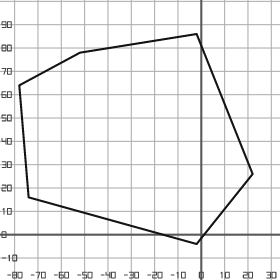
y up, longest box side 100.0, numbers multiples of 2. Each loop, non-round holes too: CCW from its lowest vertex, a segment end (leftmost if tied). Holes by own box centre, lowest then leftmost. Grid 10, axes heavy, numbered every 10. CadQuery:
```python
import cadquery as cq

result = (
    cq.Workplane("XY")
    .moveTo(-2.0, -4.0)
    .lineTo(22.0, 26.0)
    .lineTo(-2.0, 86.0)
    .lineTo(-52.0, 78.0)
    .lineTo(-78.0, 64.0)
    .lineTo(-74.0, 16.0)
    .close()
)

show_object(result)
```